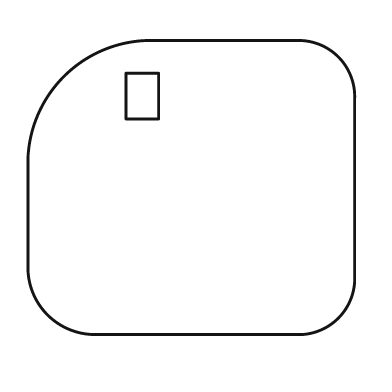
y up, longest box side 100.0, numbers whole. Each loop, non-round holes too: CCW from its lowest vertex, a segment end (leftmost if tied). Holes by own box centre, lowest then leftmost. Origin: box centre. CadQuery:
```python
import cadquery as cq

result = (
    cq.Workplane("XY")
    .moveTo(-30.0, -45.0)
    .lineTo(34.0, -45.0)
    .threePointArc((45.0, -40.0), (50.0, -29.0))
    .lineTo(50.0, 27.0)
    .threePointArc((45.0, 40.0), (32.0, 45.0))
    .lineTo(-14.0, 45.0)
    .threePointArc((-39.0, 34.0), (-50.0, 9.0))
    .lineTo(-50.0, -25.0)
    .threePointArc((-44.0, -39.0), (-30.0, -45.0))
    .close()
    .moveTo(-20.0, 21.0)
    .lineTo(-10.0, 21.0)
    .lineTo(-10.0, 35.0)
    .lineTo(-20.0, 35.0)
    .close()
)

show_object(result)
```